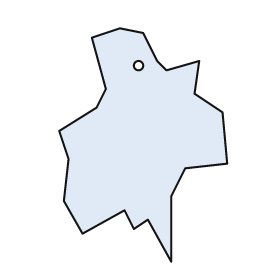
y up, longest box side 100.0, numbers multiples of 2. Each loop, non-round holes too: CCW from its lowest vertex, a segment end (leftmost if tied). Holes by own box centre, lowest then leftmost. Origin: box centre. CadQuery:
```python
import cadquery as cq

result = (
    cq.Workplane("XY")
    .moveTo(12.0, -50.0)
    .lineTo(12.0, -22.0)
    .lineTo(18.0, -10.0)
    .lineTo(36.0, -8.0)
    .lineTo(34.0, 14.0)
    .lineTo(22.0, 22.0)
    .lineTo(24.0, 36.0)
    .lineTo(10.0, 32.0)
    .lineTo(6.0, 36.0)
    .lineTo(0.0, 48.0)
    .lineTo(-10.0, 50.0)
    .lineTo(-22.0, 46.0)
    .lineTo(-16.0, 24.0)
    .lineTo(-20.0, 16.0)
    .lineTo(-36.0, 6.0)
    .lineTo(-32.0, -6.0)
    .lineTo(-34.0, -24.0)
    .lineTo(-26.0, -38.0)
    .lineTo(-8.0, -28.0)
    .lineTo(-4.0, -36.0)
    .lineTo(2.0, -32.0)
    .close()
    .moveTo(-2.0, 34.0)
    .circle(2.0)
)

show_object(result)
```